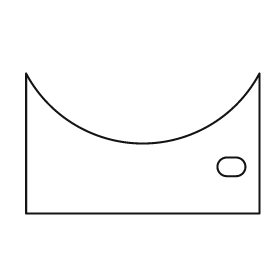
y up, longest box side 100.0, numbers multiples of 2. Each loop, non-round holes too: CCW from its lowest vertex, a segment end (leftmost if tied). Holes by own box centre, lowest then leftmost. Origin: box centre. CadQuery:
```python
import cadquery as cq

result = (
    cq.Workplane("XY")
    .moveTo(-50.0, -30.0)
    .lineTo(50.0, -30.0)
    .lineTo(50.0, 30.0)
    .threePointArc((0.0, 0.0), (-50.0, 30.0))
    .close()
    .moveTo(36.0, -14.0)
    .lineTo(40.0, -14.0)
    .threePointArc((44.0, -10.0), (40.0, -6.0))
    .lineTo(36.0, -6.0)
    .threePointArc((32.0, -10.0), (36.0, -14.0))
    .close()
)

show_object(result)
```